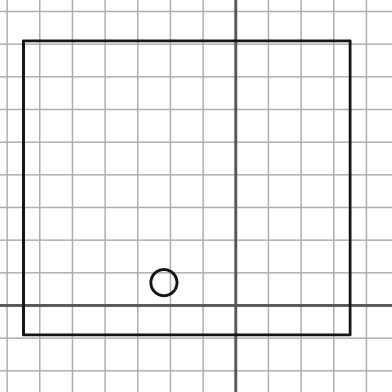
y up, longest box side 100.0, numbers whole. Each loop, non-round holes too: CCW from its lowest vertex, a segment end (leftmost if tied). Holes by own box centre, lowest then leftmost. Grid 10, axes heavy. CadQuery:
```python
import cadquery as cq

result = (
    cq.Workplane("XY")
    .moveTo(-65.0, -9.0)
    .lineTo(35.0, -9.0)
    .lineTo(35.0, 81.0)
    .lineTo(-65.0, 81.0)
    .close()
    .moveTo(-22.0, 7.0)
    .circle(4.0)
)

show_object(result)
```